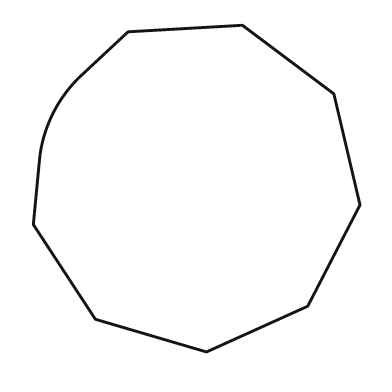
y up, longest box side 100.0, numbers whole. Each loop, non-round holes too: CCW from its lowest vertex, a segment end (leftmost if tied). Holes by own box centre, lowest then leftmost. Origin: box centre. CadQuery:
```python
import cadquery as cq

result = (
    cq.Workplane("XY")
    .moveTo(3.0, -50.0)
    .lineTo(34.0, -36.0)
    .lineTo(50.0, -5.0)
    .lineTo(42.0, 29.0)
    .lineTo(14.0, 50.0)
    .lineTo(-21.0, 48.0)
    .lineTo(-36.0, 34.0)
    .threePointArc((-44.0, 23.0), (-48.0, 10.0))
    .lineTo(-50.0, -11.0)
    .lineTo(-31.0, -40.0)
    .close()
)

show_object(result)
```